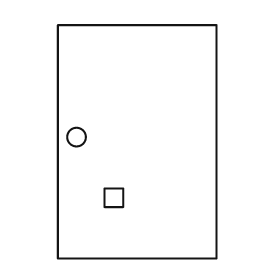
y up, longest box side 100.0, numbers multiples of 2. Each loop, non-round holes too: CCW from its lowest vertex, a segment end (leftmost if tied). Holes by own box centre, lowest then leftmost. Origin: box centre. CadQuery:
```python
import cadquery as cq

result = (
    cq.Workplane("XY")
    .moveTo(-34.0, -50.0)
    .lineTo(34.0, -50.0)
    .lineTo(34.0, 50.0)
    .lineTo(-34.0, 50.0)
    .close()
    .moveTo(-14.0, -28.0)
    .lineTo(-6.0, -28.0)
    .lineTo(-6.0, -20.0)
    .lineTo(-14.0, -20.0)
    .close()
    .moveTo(-26.0, 2.0)
    .circle(4.0)
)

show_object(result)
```